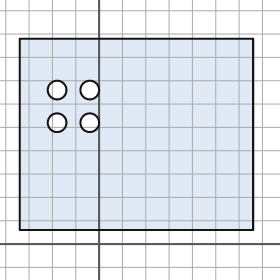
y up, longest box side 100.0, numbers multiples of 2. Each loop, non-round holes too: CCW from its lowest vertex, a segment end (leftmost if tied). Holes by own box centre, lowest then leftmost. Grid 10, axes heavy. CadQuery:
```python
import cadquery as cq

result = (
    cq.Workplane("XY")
    .moveTo(-34.0, 6.0)
    .lineTo(66.0, 6.0)
    .lineTo(66.0, 88.0)
    .lineTo(-34.0, 88.0)
    .close()
    .moveTo(-18.0, 52.0)
    .circle(4.0)
    .moveTo(-4.0, 52.0)
    .circle(4.0)
    .moveTo(-18.0, 66.0)
    .circle(4.0)
    .moveTo(-4.0, 66.0)
    .circle(4.0)
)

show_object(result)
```